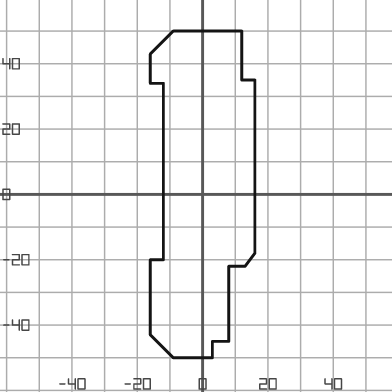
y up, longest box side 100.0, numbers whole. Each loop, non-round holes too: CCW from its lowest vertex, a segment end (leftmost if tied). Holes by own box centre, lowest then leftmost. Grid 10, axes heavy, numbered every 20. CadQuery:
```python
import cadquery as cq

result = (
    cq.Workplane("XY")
    .moveTo(-9.0, -50.0)
    .lineTo(3.0, -50.0)
    .lineTo(3.0, -45.0)
    .lineTo(8.0, -45.0)
    .lineTo(8.0, -22.0)
    .lineTo(13.0, -22.0)
    .lineTo(16.0, -18.0)
    .lineTo(16.0, 35.0)
    .lineTo(12.0, 35.0)
    .lineTo(12.0, 50.0)
    .lineTo(-9.0, 50.0)
    .lineTo(-16.0, 43.0)
    .lineTo(-16.0, 34.0)
    .lineTo(-12.0, 34.0)
    .lineTo(-12.0, -20.0)
    .lineTo(-16.0, -20.0)
    .lineTo(-16.0, -43.0)
    .close()
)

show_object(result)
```